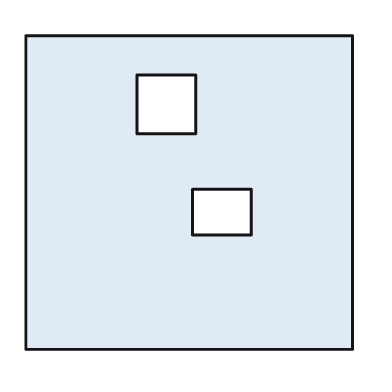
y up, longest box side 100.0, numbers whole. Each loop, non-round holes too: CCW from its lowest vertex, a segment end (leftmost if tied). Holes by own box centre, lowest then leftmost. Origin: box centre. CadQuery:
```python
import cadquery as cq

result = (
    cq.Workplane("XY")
    .moveTo(-50.0, -48.0)
    .lineTo(50.0, -48.0)
    .lineTo(50.0, 48.0)
    .lineTo(-50.0, 48.0)
    .close()
    .moveTo(1.0, -13.0)
    .lineTo(19.0, -13.0)
    .lineTo(19.0, 1.0)
    .lineTo(1.0, 1.0)
    .close()
    .moveTo(-16.0, 18.0)
    .lineTo(2.0, 18.0)
    .lineTo(2.0, 36.0)
    .lineTo(-16.0, 36.0)
    .close()
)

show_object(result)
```